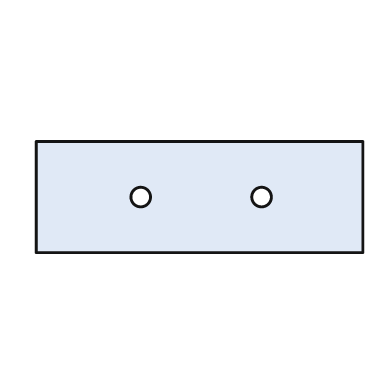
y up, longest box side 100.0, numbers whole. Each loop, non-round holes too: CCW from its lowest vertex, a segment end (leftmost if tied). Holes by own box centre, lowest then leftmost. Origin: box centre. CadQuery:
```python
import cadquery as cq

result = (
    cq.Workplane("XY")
    .moveTo(-50.0, -17.0)
    .lineTo(50.0, -17.0)
    .lineTo(50.0, 17.0)
    .lineTo(-50.0, 17.0)
    .close()
    .moveTo(-18.0, 0.0)
    .circle(3.0)
    .moveTo(19.0, 0.0)
    .circle(3.0)
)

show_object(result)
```